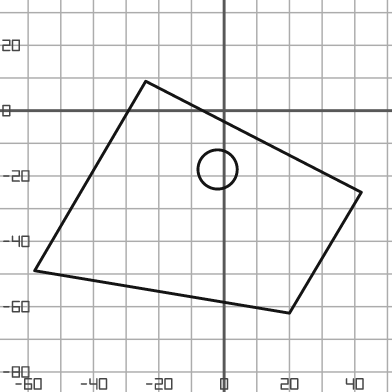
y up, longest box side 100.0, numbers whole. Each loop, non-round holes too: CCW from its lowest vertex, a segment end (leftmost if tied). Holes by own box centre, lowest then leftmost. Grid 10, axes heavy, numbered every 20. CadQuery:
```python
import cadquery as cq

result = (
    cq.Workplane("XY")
    .moveTo(20.0, -62.0)
    .lineTo(42.0, -25.0)
    .lineTo(-24.0, 9.0)
    .lineTo(-58.0, -49.0)
    .close()
    .moveTo(-2.0, -18.0)
    .circle(6.0)
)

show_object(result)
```